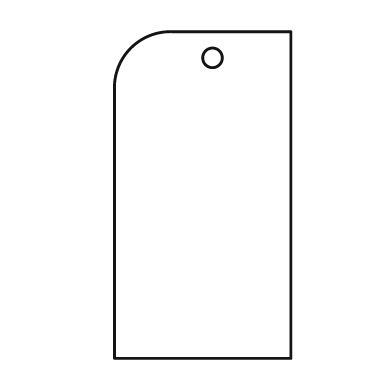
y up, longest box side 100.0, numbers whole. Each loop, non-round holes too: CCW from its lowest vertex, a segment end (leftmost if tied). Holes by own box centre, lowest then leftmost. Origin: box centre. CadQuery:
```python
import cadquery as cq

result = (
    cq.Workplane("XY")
    .moveTo(-27.0, -50.0)
    .lineTo(27.0, -50.0)
    .lineTo(27.0, 50.0)
    .lineTo(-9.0, 50.0)
    .threePointArc((-22.0, 45.0), (-27.0, 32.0))
    .close()
    .moveTo(3.0, 42.0)
    .circle(3.0)
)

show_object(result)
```